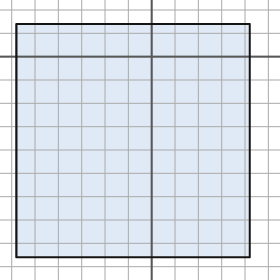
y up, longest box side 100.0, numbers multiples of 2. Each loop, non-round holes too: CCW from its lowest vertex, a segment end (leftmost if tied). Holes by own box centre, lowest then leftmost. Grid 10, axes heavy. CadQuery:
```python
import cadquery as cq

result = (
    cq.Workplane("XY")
    .moveTo(-58.0, -86.0)
    .lineTo(42.0, -86.0)
    .lineTo(42.0, 14.0)
    .lineTo(-58.0, 14.0)
    .close()
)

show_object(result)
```